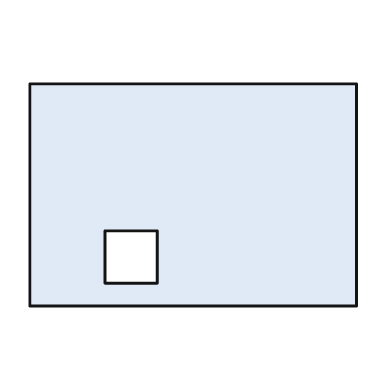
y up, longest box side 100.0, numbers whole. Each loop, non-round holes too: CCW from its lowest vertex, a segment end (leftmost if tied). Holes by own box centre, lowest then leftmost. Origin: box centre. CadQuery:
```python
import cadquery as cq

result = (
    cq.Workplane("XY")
    .moveTo(-50.0, -34.0)
    .lineTo(50.0, -34.0)
    .lineTo(50.0, 34.0)
    .lineTo(-50.0, 34.0)
    .close()
    .moveTo(-27.0, -27.0)
    .lineTo(-11.0, -27.0)
    .lineTo(-11.0, -11.0)
    .lineTo(-27.0, -11.0)
    .close()
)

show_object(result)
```